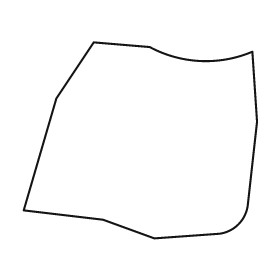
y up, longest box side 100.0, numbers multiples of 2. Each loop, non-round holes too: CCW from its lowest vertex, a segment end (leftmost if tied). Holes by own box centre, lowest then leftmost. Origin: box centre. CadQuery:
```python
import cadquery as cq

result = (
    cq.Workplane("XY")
    .moveTo(6.0, -42.0)
    .lineTo(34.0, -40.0)
    .threePointArc((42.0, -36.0), (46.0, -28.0))
    .lineTo(50.0, 8.0)
    .lineTo(48.0, 38.0)
    .threePointArc((26.0, 34.0), (4.0, 40.0))
    .lineTo(-20.0, 42.0)
    .lineTo(-36.0, 18.0)
    .lineTo(-50.0, -30.0)
    .lineTo(-16.0, -34.0)
    .close()
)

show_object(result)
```